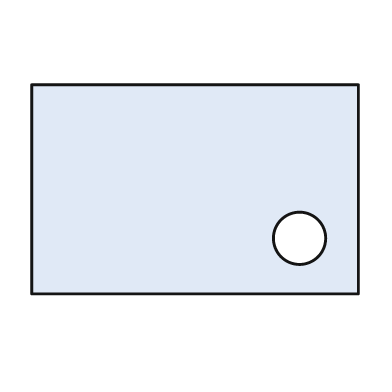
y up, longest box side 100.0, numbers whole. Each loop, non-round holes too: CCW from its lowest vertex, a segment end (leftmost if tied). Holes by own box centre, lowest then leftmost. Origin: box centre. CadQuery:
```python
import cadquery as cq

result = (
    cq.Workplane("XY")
    .moveTo(-50.0, -32.0)
    .lineTo(50.0, -32.0)
    .lineTo(50.0, 32.0)
    .lineTo(-50.0, 32.0)
    .close()
    .moveTo(32.0, -15.0)
    .circle(8.0)
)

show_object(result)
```